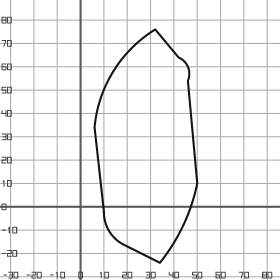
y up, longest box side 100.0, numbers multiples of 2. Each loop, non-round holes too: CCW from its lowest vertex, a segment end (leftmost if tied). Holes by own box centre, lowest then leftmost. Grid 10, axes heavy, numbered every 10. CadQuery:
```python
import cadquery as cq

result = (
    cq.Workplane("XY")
    .moveTo(34.0, -24.0)
    .threePointArc((44.0, -8.0), (50.0, 10.0))
    .lineTo(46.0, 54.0)
    .threePointArc((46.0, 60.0), (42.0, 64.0))
    .lineTo(32.0, 76.0)
    .threePointArc((14.0, 58.0), (6.0, 34.0))
    .lineTo(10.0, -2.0)
    .threePointArc((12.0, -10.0), (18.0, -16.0))
    .close()
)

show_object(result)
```